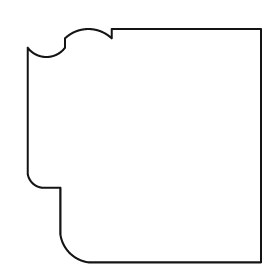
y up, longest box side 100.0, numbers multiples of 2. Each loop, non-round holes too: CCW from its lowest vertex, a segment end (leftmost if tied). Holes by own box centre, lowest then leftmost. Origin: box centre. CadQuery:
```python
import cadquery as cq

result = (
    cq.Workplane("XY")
    .moveTo(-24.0, -50.0)
    .lineTo(50.0, -50.0)
    .lineTo(50.0, 50.0)
    .lineTo(-14.0, 50.0)
    .lineTo(-14.0, 46.0)
    .threePointArc((-24.0, 50.0), (-34.0, 46.0))
    .lineTo(-34.0, 42.0)
    .threePointArc((-42.0, 38.0), (-50.0, 42.0))
    .lineTo(-50.0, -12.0)
    .threePointArc((-48.0, -16.0), (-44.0, -18.0))
    .lineTo(-36.0, -18.0)
    .lineTo(-36.0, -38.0)
    .threePointArc((-32.0, -46.0), (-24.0, -50.0))
    .close()
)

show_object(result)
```